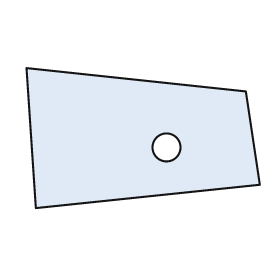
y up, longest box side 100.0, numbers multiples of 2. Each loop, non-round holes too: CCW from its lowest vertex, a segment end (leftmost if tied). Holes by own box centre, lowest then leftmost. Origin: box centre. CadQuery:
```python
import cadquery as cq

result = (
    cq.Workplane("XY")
    .moveTo(-46.0, -30.0)
    .lineTo(50.0, -20.0)
    .lineTo(44.0, 20.0)
    .lineTo(-50.0, 30.0)
    .close()
    .moveTo(10.0, -4.0)
    .circle(6.0)
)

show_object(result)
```